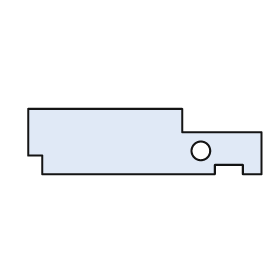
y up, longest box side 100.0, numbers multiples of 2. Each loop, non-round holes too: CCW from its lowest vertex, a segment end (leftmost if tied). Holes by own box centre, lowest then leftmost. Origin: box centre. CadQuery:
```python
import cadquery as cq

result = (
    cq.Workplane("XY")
    .moveTo(-44.0, -14.0)
    .lineTo(30.0, -14.0)
    .lineTo(30.0, -10.0)
    .lineTo(42.0, -10.0)
    .lineTo(42.0, -14.0)
    .lineTo(50.0, -14.0)
    .lineTo(50.0, 4.0)
    .lineTo(16.0, 4.0)
    .lineTo(16.0, 14.0)
    .lineTo(-50.0, 14.0)
    .lineTo(-50.0, -6.0)
    .lineTo(-44.0, -6.0)
    .close()
    .moveTo(24.0, -4.0)
    .circle(4.0)
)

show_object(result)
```